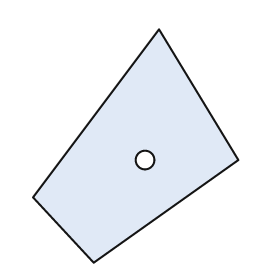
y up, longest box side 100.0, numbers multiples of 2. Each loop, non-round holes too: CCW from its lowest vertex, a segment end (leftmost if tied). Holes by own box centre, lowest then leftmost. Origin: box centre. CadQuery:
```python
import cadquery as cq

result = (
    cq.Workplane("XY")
    .moveTo(-18.0, -50.0)
    .lineTo(44.0, -6.0)
    .lineTo(10.0, 50.0)
    .lineTo(-44.0, -22.0)
    .close()
    .moveTo(4.0, -6.0)
    .circle(4.0)
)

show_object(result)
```